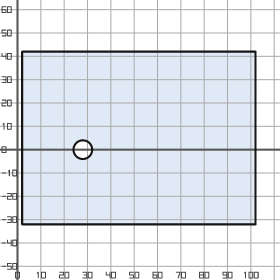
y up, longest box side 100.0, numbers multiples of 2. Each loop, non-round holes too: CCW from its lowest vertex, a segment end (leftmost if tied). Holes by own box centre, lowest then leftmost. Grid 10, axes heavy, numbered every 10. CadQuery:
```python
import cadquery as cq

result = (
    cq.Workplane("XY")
    .moveTo(2.0, -32.0)
    .lineTo(102.0, -32.0)
    .lineTo(102.0, 42.0)
    .lineTo(2.0, 42.0)
    .close()
    .moveTo(28.0, 0.0)
    .circle(4.0)
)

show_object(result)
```